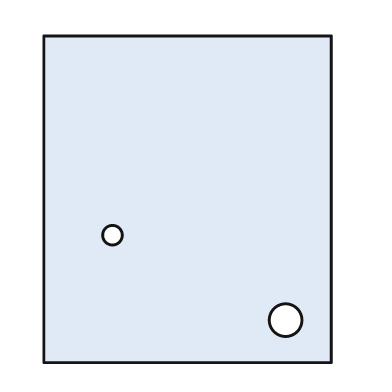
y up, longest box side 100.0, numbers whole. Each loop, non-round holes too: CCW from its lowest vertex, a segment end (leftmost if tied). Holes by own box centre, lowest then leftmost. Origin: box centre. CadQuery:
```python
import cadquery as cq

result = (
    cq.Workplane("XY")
    .moveTo(-44.0, -50.0)
    .lineTo(44.0, -50.0)
    .lineTo(44.0, 50.0)
    .lineTo(-44.0, 50.0)
    .close()
    .moveTo(30.0, -37.0)
    .circle(5.0)
    .moveTo(-23.0, -11.0)
    .circle(3.0)
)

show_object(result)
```